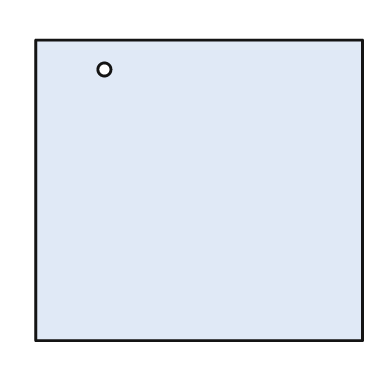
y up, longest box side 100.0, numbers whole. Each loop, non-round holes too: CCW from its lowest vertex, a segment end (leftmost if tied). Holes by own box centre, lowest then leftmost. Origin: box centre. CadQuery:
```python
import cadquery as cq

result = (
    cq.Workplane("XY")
    .moveTo(-50.0, -46.0)
    .lineTo(50.0, -46.0)
    .lineTo(50.0, 46.0)
    .lineTo(-50.0, 46.0)
    .close()
    .moveTo(-29.0, 37.0)
    .circle(2.0)
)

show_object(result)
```